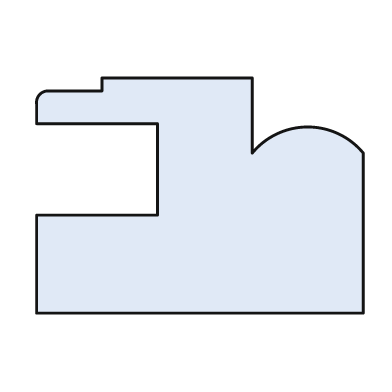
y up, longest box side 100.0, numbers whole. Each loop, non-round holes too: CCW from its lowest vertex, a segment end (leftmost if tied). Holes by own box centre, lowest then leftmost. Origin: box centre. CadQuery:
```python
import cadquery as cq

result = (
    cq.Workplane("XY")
    .moveTo(-50.0, -36.0)
    .lineTo(50.0, -36.0)
    .lineTo(50.0, 13.0)
    .threePointArc((33.0, 21.0), (16.0, 13.0))
    .lineTo(16.0, 36.0)
    .lineTo(-30.0, 36.0)
    .lineTo(-30.0, 32.0)
    .lineTo(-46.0, 32.0)
    .threePointArc((-49.0, 31.0), (-50.0, 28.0))
    .lineTo(-50.0, 22.0)
    .lineTo(-13.0, 22.0)
    .lineTo(-13.0, -6.0)
    .lineTo(-50.0, -6.0)
    .close()
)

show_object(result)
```